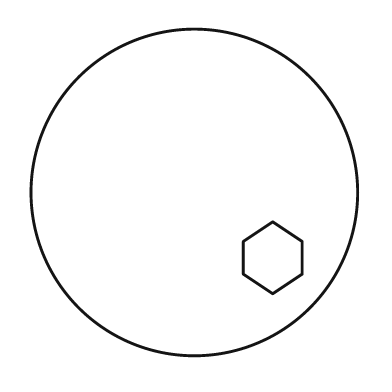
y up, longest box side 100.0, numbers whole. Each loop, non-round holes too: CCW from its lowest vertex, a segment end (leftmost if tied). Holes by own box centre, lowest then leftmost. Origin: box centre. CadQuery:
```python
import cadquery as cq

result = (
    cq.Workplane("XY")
    .moveTo(0.0, 0.0)
    .circle(50.0)
    .moveTo(24.0, -31.0)
    .lineTo(33.0, -25.0)
    .lineTo(33.0, -15.0)
    .lineTo(24.0, -9.0)
    .lineTo(15.0, -15.0)
    .lineTo(15.0, -25.0)
    .close()
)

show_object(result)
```